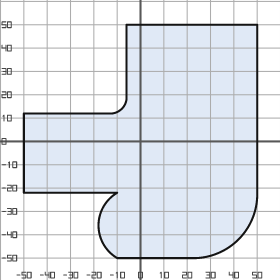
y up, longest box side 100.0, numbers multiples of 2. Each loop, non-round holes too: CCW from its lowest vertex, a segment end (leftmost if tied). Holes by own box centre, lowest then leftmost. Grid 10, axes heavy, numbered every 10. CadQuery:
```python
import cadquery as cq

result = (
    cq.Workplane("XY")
    .moveTo(-10.0, -50.0)
    .lineTo(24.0, -50.0)
    .threePointArc((42.0, -42.0), (50.0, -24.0))
    .lineTo(50.0, 50.0)
    .lineTo(-6.0, 50.0)
    .lineTo(-6.0, 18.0)
    .threePointArc((-8.0, 14.0), (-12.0, 12.0))
    .lineTo(-50.0, 12.0)
    .lineTo(-50.0, -22.0)
    .lineTo(-10.0, -22.0)
    .threePointArc((-18.0, -36.0), (-10.0, -50.0))
    .close()
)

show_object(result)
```